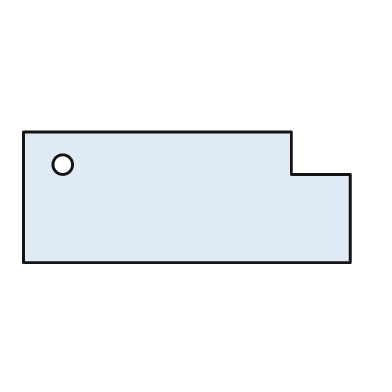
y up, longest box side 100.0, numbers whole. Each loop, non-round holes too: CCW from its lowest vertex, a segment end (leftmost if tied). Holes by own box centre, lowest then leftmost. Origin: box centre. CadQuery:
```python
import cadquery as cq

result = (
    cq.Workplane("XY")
    .moveTo(-50.0, -20.0)
    .lineTo(50.0, -20.0)
    .lineTo(50.0, 7.0)
    .lineTo(32.0, 7.0)
    .lineTo(32.0, 20.0)
    .lineTo(-50.0, 20.0)
    .close()
    .moveTo(-38.0, 10.0)
    .circle(3.0)
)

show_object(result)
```